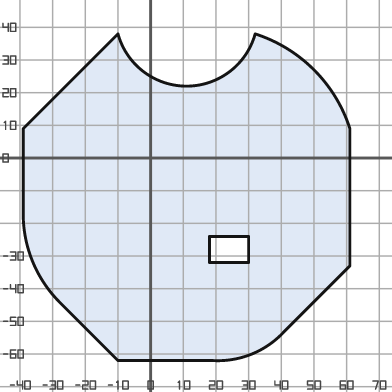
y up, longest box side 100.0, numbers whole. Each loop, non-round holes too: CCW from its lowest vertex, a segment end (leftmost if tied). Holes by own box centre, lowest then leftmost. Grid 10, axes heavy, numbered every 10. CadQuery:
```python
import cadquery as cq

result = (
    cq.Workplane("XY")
    .moveTo(-10.0, -62.0)
    .lineTo(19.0, -62.0)
    .threePointArc((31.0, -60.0), (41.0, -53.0))
    .lineTo(61.0, -33.0)
    .lineTo(61.0, 9.0)
    .threePointArc((50.0, 27.0), (32.0, 38.0))
    .threePointArc((11.0, 22.0), (-10.0, 38.0))
    .lineTo(-39.0, 9.0)
    .lineTo(-39.0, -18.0)
    .threePointArc((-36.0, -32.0), (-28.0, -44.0))
    .close()
    .moveTo(18.0, -32.0)
    .lineTo(30.0, -32.0)
    .lineTo(30.0, -24.0)
    .lineTo(18.0, -24.0)
    .close()
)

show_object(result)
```